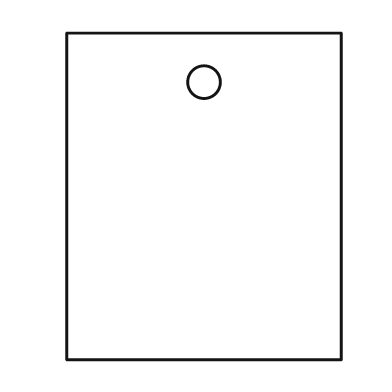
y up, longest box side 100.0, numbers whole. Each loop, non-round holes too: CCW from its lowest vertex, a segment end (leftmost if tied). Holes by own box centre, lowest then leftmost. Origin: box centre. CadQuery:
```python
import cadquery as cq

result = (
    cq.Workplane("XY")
    .moveTo(-42.0, -50.0)
    .lineTo(42.0, -50.0)
    .lineTo(42.0, 50.0)
    .lineTo(-42.0, 50.0)
    .close()
    .moveTo(0.0, 35.0)
    .circle(5.0)
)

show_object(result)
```